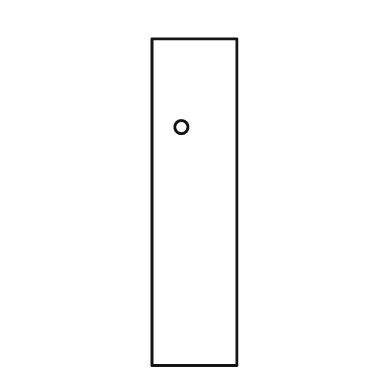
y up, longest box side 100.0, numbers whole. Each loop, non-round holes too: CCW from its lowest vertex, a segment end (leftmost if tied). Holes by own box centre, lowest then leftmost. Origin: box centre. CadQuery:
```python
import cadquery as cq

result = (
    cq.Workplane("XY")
    .moveTo(-13.0, -50.0)
    .lineTo(13.0, -50.0)
    .lineTo(13.0, 50.0)
    .lineTo(-13.0, 50.0)
    .close()
    .moveTo(-4.0, 23.0)
    .circle(2.0)
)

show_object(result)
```